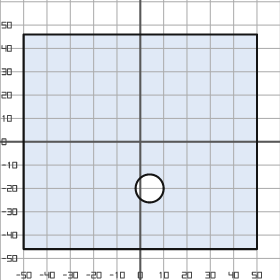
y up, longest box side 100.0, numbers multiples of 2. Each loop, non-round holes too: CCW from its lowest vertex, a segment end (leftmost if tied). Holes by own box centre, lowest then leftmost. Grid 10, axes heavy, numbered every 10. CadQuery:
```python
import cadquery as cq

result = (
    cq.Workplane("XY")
    .moveTo(-50.0, -46.0)
    .lineTo(50.0, -46.0)
    .lineTo(50.0, 46.0)
    .lineTo(-50.0, 46.0)
    .close()
    .moveTo(4.0, -20.0)
    .circle(6.0)
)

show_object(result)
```